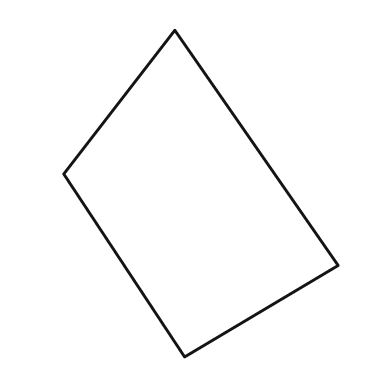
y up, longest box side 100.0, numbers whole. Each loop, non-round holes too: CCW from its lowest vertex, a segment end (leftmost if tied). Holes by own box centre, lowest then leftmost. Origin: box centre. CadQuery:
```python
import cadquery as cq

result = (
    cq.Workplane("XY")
    .moveTo(-5.0, -50.0)
    .lineTo(42.0, -22.0)
    .lineTo(-8.0, 50.0)
    .lineTo(-42.0, 6.0)
    .close()
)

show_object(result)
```